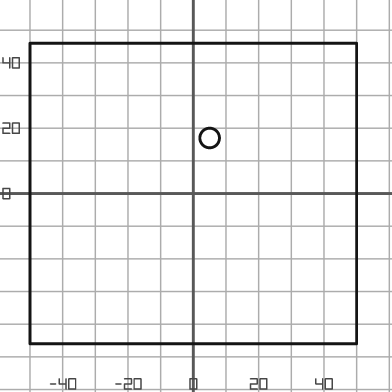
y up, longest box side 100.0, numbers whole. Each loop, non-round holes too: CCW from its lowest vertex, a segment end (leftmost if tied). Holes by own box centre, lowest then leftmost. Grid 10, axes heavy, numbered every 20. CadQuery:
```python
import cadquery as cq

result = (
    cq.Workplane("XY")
    .moveTo(-50.0, -46.0)
    .lineTo(50.0, -46.0)
    .lineTo(50.0, 46.0)
    .lineTo(-50.0, 46.0)
    .close()
    .moveTo(5.0, 17.0)
    .circle(3.0)
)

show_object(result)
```